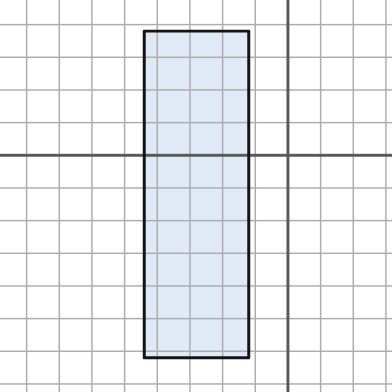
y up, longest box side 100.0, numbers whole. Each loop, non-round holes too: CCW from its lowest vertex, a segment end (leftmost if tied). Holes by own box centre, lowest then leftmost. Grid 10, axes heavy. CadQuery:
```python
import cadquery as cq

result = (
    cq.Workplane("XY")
    .moveTo(-44.0, -62.0)
    .lineTo(-12.0, -62.0)
    .lineTo(-12.0, 38.0)
    .lineTo(-44.0, 38.0)
    .close()
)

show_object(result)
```